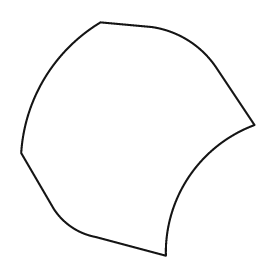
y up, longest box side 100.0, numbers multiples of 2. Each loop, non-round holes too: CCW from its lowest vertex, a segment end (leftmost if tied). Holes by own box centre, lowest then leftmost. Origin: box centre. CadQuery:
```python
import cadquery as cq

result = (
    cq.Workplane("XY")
    .moveTo(12.0, -50.0)
    .threePointArc((22.0, -16.0), (50.0, 6.0))
    .lineTo(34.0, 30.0)
    .threePointArc((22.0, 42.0), (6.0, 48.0))
    .lineTo(-16.0, 50.0)
    .threePointArc((-40.0, 26.0), (-50.0, -6.0))
    .lineTo(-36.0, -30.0)
    .threePointArc((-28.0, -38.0), (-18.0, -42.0))
    .close()
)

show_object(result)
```